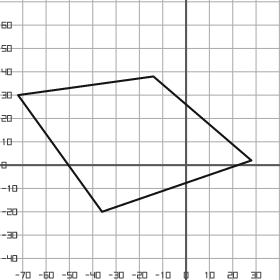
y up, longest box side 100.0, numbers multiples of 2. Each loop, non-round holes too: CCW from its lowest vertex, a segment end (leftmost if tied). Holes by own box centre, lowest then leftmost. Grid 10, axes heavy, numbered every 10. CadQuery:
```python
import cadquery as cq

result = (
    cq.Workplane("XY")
    .moveTo(-36.0, -20.0)
    .lineTo(28.0, 2.0)
    .lineTo(-14.0, 38.0)
    .lineTo(-72.0, 30.0)
    .close()
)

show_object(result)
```